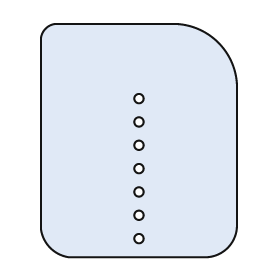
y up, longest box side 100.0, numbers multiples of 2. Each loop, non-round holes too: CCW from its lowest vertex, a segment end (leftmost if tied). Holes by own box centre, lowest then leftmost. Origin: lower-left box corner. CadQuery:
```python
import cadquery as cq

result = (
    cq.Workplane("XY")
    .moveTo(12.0, 0.0)
    .lineTo(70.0, 0.0)
    .threePointArc((80.0, 4.0), (84.0, 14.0))
    .lineTo(84.0, 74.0)
    .threePointArc((76.0, 92.0), (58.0, 100.0))
    .lineTo(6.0, 100.0)
    .threePointArc((2.0, 98.0), (0.0, 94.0))
    .lineTo(0.0, 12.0)
    .threePointArc((4.0, 4.0), (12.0, 0.0))
    .close()
    .moveTo(42.0, 8.0)
    .circle(2.0)
    .moveTo(42.0, 18.0)
    .circle(2.0)
    .moveTo(42.0, 28.0)
    .circle(2.0)
    .moveTo(42.0, 38.0)
    .circle(2.0)
    .moveTo(42.0, 48.0)
    .circle(2.0)
    .moveTo(42.0, 58.0)
    .circle(2.0)
    .moveTo(42.0, 68.0)
    .circle(2.0)
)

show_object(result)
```